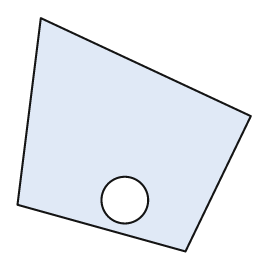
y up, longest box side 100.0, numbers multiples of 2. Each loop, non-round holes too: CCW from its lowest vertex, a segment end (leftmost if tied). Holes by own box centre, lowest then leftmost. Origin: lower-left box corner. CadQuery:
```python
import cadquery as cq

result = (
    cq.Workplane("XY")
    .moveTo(72.0, 0.0)
    .lineTo(100.0, 58.0)
    .lineTo(10.0, 100.0)
    .lineTo(0.0, 20.0)
    .close()
    .moveTo(46.0, 22.0)
    .circle(10.0)
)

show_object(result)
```